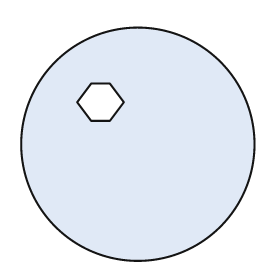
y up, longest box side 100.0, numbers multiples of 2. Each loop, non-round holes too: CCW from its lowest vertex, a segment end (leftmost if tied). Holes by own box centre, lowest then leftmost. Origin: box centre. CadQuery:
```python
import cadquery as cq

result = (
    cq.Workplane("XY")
    .moveTo(0.0, 0.0)
    .circle(50.0)
    .moveTo(-20.0, 10.0)
    .lineTo(-12.0, 10.0)
    .lineTo(-6.0, 18.0)
    .lineTo(-12.0, 26.0)
    .lineTo(-20.0, 26.0)
    .lineTo(-26.0, 18.0)
    .close()
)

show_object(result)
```